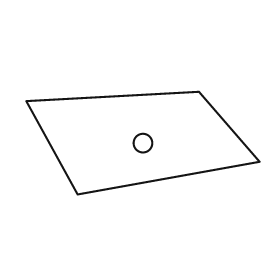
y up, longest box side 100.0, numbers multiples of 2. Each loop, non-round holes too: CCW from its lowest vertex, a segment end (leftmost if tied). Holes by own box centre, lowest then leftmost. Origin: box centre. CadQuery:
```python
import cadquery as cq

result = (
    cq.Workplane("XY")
    .moveTo(-28.0, -22.0)
    .lineTo(50.0, -8.0)
    .lineTo(24.0, 22.0)
    .lineTo(-50.0, 18.0)
    .close()
    .moveTo(0.0, 0.0)
    .circle(4.0)
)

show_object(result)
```